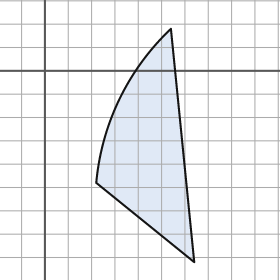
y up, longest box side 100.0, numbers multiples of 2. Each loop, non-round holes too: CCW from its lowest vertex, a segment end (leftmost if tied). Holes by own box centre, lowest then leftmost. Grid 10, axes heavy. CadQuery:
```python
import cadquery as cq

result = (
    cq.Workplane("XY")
    .moveTo(64.0, -82.0)
    .lineTo(54.0, 18.0)
    .threePointArc((32.0, -12.0), (22.0, -48.0))
    .close()
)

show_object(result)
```